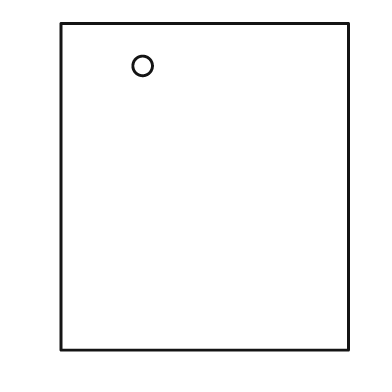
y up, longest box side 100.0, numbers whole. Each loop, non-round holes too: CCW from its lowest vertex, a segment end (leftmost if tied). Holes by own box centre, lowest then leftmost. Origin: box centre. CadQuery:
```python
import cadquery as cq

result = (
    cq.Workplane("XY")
    .moveTo(-44.0, -50.0)
    .lineTo(44.0, -50.0)
    .lineTo(44.0, 50.0)
    .lineTo(-44.0, 50.0)
    .close()
    .moveTo(-19.0, 37.0)
    .circle(3.0)
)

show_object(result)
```